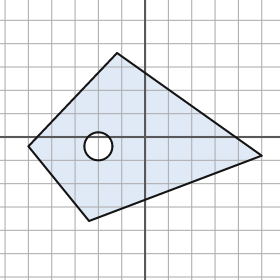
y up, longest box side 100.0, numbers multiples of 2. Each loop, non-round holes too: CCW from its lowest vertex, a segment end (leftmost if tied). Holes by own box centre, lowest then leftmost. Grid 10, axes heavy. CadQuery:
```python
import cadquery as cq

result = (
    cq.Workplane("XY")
    .moveTo(-24.0, -36.0)
    .lineTo(50.0, -8.0)
    .lineTo(-12.0, 36.0)
    .lineTo(-50.0, -4.0)
    .close()
    .moveTo(-20.0, -4.0)
    .circle(6.0)
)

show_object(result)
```